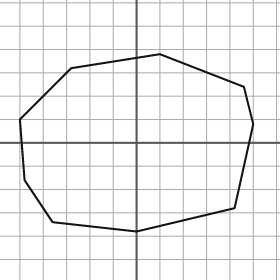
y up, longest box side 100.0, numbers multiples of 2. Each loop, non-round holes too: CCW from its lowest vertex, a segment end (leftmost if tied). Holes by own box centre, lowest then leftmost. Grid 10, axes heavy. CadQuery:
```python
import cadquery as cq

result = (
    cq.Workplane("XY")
    .moveTo(0.0, -38.0)
    .lineTo(42.0, -28.0)
    .lineTo(50.0, 8.0)
    .lineTo(46.0, 24.0)
    .lineTo(10.0, 38.0)
    .lineTo(-28.0, 32.0)
    .lineTo(-50.0, 10.0)
    .lineTo(-48.0, -16.0)
    .lineTo(-36.0, -34.0)
    .close()
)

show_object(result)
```